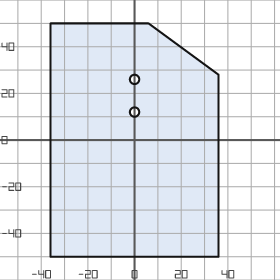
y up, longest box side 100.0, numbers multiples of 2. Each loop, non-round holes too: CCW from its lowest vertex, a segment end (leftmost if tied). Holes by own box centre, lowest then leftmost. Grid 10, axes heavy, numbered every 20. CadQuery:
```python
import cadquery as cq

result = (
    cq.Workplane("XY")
    .moveTo(-36.0, -50.0)
    .lineTo(36.0, -50.0)
    .lineTo(36.0, 28.0)
    .lineTo(6.0, 50.0)
    .lineTo(-36.0, 50.0)
    .close()
    .moveTo(0.0, 12.0)
    .circle(2.0)
    .moveTo(0.0, 26.0)
    .circle(2.0)
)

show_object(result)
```